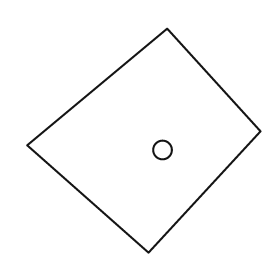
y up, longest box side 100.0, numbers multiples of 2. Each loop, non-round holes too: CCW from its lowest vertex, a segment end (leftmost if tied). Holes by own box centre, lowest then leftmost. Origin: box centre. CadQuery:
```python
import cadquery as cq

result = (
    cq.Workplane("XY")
    .moveTo(2.0, -48.0)
    .lineTo(50.0, 4.0)
    .lineTo(10.0, 48.0)
    .lineTo(-50.0, -2.0)
    .close()
    .moveTo(8.0, -4.0)
    .circle(4.0)
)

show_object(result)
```